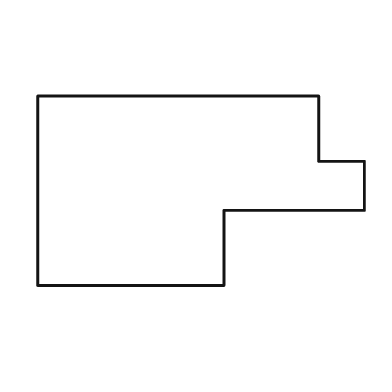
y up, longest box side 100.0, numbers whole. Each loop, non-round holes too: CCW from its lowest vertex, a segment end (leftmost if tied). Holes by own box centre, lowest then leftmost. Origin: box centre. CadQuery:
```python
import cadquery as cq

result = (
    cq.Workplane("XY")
    .moveTo(-50.0, -29.0)
    .lineTo(7.0, -29.0)
    .lineTo(7.0, -6.0)
    .lineTo(50.0, -6.0)
    .lineTo(50.0, 9.0)
    .lineTo(36.0, 9.0)
    .lineTo(36.0, 29.0)
    .lineTo(-50.0, 29.0)
    .close()
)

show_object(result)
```